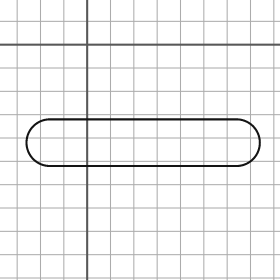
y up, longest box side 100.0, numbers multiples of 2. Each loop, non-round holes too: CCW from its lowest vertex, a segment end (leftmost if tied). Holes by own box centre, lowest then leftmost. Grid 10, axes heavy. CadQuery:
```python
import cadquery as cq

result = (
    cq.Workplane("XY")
    .moveTo(-16.0, -52.0)
    .lineTo(64.0, -52.0)
    .threePointArc((74.0, -42.0), (64.0, -32.0))
    .lineTo(-16.0, -32.0)
    .threePointArc((-26.0, -42.0), (-16.0, -52.0))
    .close()
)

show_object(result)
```